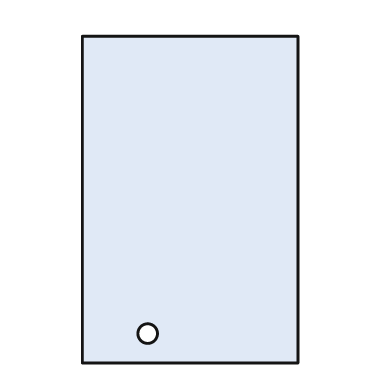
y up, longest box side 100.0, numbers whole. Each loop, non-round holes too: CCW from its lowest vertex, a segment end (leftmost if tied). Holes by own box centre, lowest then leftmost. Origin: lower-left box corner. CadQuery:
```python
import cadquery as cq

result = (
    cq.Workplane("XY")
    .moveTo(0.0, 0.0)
    .lineTo(66.0, 0.0)
    .lineTo(66.0, 100.0)
    .lineTo(0.0, 100.0)
    .close()
    .moveTo(20.0, 9.0)
    .circle(3.0)
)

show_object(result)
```